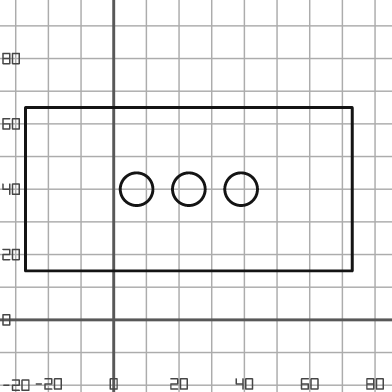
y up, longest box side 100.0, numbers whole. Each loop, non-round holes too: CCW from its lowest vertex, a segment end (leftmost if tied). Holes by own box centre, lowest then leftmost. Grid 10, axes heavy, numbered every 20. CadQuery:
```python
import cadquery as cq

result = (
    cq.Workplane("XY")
    .moveTo(-27.0, 15.0)
    .lineTo(73.0, 15.0)
    .lineTo(73.0, 65.0)
    .lineTo(-27.0, 65.0)
    .close()
    .moveTo(7.0, 40.0)
    .circle(5.0)
    .moveTo(23.0, 40.0)
    .circle(5.0)
    .moveTo(39.0, 40.0)
    .circle(5.0)
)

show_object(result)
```